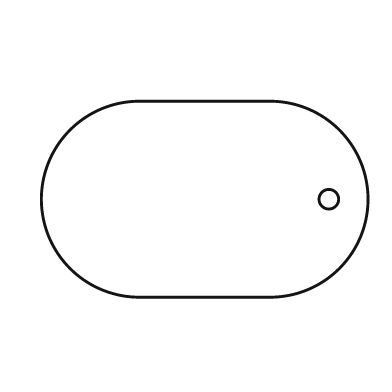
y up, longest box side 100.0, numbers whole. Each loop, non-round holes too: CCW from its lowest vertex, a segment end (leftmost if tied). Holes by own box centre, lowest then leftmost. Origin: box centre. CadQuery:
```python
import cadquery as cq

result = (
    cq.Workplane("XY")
    .moveTo(-20.0, -30.0)
    .lineTo(20.0, -30.0)
    .threePointArc((50.0, 0.0), (20.0, 30.0))
    .lineTo(-20.0, 30.0)
    .threePointArc((-50.0, 0.0), (-20.0, -30.0))
    .close()
    .moveTo(38.0, 0.0)
    .circle(3.0)
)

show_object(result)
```